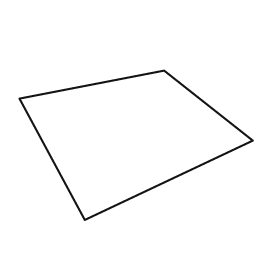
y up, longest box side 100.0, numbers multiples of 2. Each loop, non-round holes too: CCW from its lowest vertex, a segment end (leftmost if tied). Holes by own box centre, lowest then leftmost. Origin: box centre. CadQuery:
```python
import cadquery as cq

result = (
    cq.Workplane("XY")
    .moveTo(-22.0, -32.0)
    .lineTo(50.0, 2.0)
    .lineTo(12.0, 32.0)
    .lineTo(-50.0, 20.0)
    .close()
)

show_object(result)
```